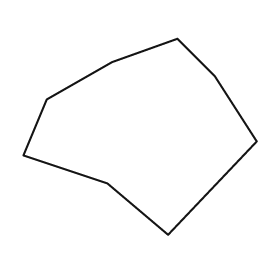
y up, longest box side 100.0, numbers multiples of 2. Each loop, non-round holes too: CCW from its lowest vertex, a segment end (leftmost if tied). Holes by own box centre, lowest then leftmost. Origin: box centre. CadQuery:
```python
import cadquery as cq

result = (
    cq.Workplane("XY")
    .moveTo(12.0, -42.0)
    .lineTo(50.0, -2.0)
    .lineTo(32.0, 26.0)
    .lineTo(16.0, 42.0)
    .lineTo(-12.0, 32.0)
    .lineTo(-40.0, 16.0)
    .lineTo(-50.0, -8.0)
    .lineTo(-14.0, -20.0)
    .close()
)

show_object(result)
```